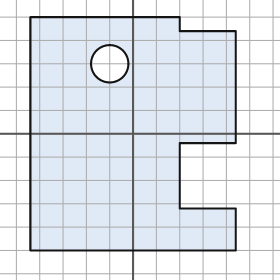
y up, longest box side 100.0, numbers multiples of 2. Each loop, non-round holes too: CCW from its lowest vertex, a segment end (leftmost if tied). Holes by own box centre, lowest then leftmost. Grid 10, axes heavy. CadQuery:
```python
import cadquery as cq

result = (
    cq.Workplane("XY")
    .moveTo(-44.0, -50.0)
    .lineTo(44.0, -50.0)
    .lineTo(44.0, -32.0)
    .lineTo(20.0, -32.0)
    .lineTo(20.0, -4.0)
    .lineTo(44.0, -4.0)
    .lineTo(44.0, 44.0)
    .lineTo(20.0, 44.0)
    .lineTo(20.0, 50.0)
    .lineTo(-44.0, 50.0)
    .close()
    .moveTo(-10.0, 30.0)
    .circle(8.0)
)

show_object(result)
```